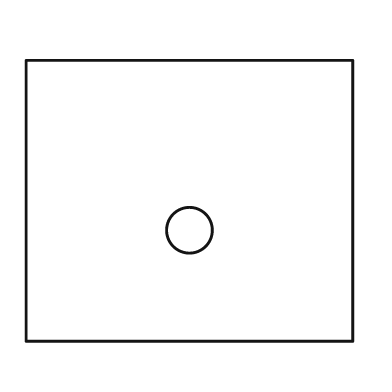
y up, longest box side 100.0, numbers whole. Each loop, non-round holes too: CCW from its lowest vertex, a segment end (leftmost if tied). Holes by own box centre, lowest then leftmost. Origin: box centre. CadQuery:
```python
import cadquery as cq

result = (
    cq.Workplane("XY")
    .moveTo(-50.0, -43.0)
    .lineTo(50.0, -43.0)
    .lineTo(50.0, 43.0)
    .lineTo(-50.0, 43.0)
    .close()
    .moveTo(0.0, -9.0)
    .circle(7.0)
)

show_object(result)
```